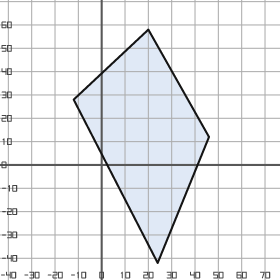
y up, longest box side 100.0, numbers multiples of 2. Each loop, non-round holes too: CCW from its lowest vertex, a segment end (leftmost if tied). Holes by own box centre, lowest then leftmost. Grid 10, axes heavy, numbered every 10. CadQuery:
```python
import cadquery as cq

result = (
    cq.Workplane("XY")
    .moveTo(24.0, -42.0)
    .lineTo(46.0, 12.0)
    .lineTo(20.0, 58.0)
    .lineTo(-12.0, 28.0)
    .close()
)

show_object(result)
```